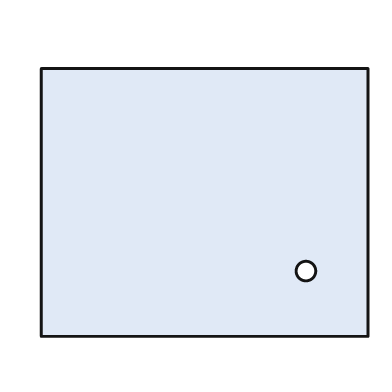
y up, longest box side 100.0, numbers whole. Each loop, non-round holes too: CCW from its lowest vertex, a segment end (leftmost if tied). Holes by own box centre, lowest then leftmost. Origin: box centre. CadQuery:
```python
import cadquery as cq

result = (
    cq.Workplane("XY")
    .moveTo(-50.0, -41.0)
    .lineTo(50.0, -41.0)
    .lineTo(50.0, 41.0)
    .lineTo(-50.0, 41.0)
    .close()
    .moveTo(31.0, -21.0)
    .circle(3.0)
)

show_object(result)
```